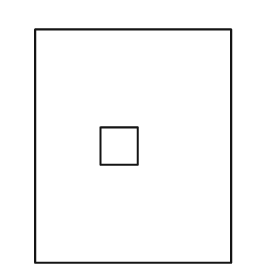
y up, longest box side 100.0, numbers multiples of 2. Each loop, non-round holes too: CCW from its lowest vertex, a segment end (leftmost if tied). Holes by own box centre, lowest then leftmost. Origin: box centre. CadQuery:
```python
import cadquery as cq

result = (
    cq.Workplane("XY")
    .moveTo(-42.0, -50.0)
    .lineTo(42.0, -50.0)
    .lineTo(42.0, 50.0)
    .lineTo(-42.0, 50.0)
    .close()
    .moveTo(-14.0, -8.0)
    .lineTo(2.0, -8.0)
    .lineTo(2.0, 8.0)
    .lineTo(-14.0, 8.0)
    .close()
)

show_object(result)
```